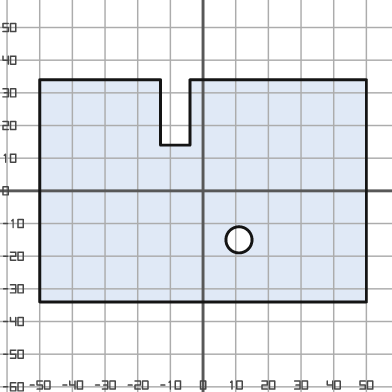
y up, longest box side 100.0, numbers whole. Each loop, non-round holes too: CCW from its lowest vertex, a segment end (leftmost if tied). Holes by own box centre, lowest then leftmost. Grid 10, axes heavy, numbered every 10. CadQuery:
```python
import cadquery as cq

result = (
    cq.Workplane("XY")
    .moveTo(-50.0, -34.0)
    .lineTo(50.0, -34.0)
    .lineTo(50.0, 34.0)
    .lineTo(-4.0, 34.0)
    .lineTo(-4.0, 14.0)
    .lineTo(-13.0, 14.0)
    .lineTo(-13.0, 34.0)
    .lineTo(-50.0, 34.0)
    .close()
    .moveTo(11.0, -15.0)
    .circle(4.0)
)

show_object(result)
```